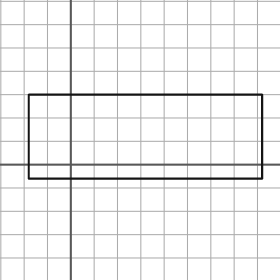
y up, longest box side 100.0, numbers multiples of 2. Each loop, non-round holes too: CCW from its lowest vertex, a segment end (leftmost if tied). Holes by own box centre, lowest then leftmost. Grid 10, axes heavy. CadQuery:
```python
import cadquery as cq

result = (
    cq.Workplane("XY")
    .moveTo(-18.0, -6.0)
    .lineTo(82.0, -6.0)
    .lineTo(82.0, 30.0)
    .lineTo(-18.0, 30.0)
    .close()
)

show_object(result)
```